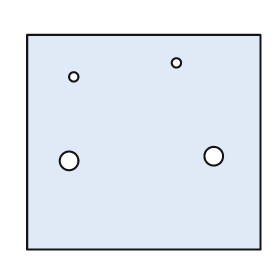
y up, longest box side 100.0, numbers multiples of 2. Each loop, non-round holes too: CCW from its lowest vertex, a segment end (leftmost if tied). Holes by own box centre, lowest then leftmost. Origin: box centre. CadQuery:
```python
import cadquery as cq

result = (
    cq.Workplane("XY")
    .moveTo(-50.0, -46.0)
    .lineTo(50.0, -46.0)
    .lineTo(50.0, 46.0)
    .lineTo(-50.0, 46.0)
    .close()
    .moveTo(-32.0, -8.0)
    .circle(4.0)
    .moveTo(30.0, -6.0)
    .circle(4.0)
    .moveTo(-30.0, 28.0)
    .circle(2.0)
    .moveTo(14.0, 34.0)
    .circle(2.0)
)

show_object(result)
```